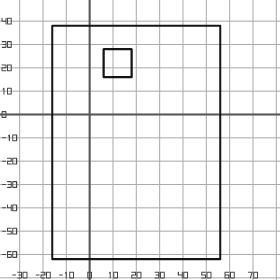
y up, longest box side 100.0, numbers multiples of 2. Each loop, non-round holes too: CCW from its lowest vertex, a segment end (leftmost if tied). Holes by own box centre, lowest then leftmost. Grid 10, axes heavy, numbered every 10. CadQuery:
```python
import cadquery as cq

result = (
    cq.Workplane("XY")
    .moveTo(-16.0, -62.0)
    .lineTo(56.0, -62.0)
    .lineTo(56.0, 38.0)
    .lineTo(-16.0, 38.0)
    .close()
    .moveTo(6.0, 16.0)
    .lineTo(18.0, 16.0)
    .lineTo(18.0, 28.0)
    .lineTo(6.0, 28.0)
    .close()
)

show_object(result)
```